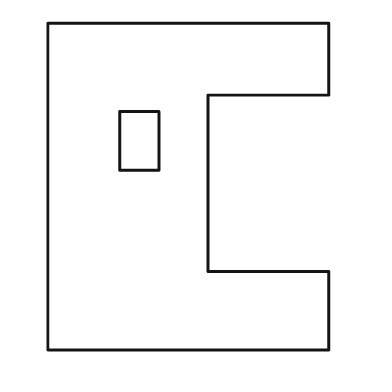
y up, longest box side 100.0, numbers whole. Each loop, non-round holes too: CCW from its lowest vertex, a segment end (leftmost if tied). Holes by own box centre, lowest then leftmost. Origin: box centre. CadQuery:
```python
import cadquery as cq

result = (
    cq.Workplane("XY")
    .moveTo(-43.0, -50.0)
    .lineTo(43.0, -50.0)
    .lineTo(43.0, -26.0)
    .lineTo(6.0, -26.0)
    .lineTo(6.0, 28.0)
    .lineTo(43.0, 28.0)
    .lineTo(43.0, 50.0)
    .lineTo(-43.0, 50.0)
    .close()
    .moveTo(-21.0, 5.0)
    .lineTo(-9.0, 5.0)
    .lineTo(-9.0, 23.0)
    .lineTo(-21.0, 23.0)
    .close()
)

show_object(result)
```